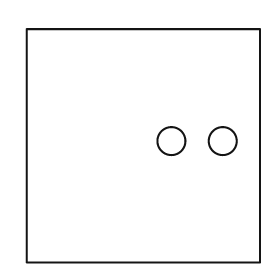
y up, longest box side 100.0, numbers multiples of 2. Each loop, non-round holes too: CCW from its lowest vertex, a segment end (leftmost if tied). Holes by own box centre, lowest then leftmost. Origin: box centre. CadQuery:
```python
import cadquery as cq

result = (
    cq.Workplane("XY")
    .moveTo(-50.0, -50.0)
    .lineTo(50.0, -50.0)
    .lineTo(50.0, 50.0)
    .lineTo(-50.0, 50.0)
    .close()
    .moveTo(12.0, 2.0)
    .circle(6.0)
    .moveTo(34.0, 2.0)
    .circle(6.0)
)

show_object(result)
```